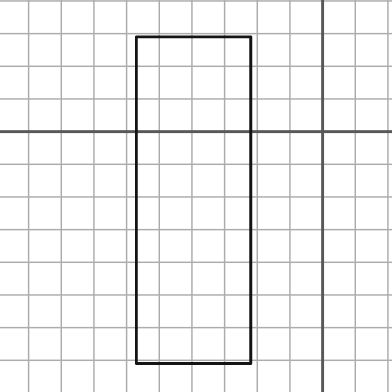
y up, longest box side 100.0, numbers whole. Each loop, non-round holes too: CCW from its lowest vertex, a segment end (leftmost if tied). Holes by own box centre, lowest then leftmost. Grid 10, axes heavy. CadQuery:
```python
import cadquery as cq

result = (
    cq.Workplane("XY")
    .moveTo(-57.0, -71.0)
    .lineTo(-22.0, -71.0)
    .lineTo(-22.0, 29.0)
    .lineTo(-57.0, 29.0)
    .close()
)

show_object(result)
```